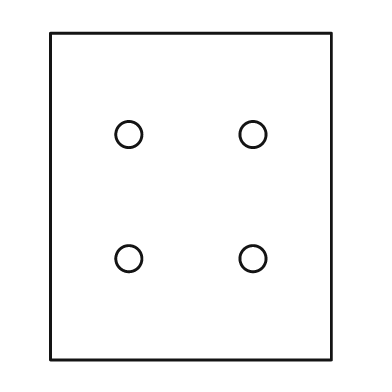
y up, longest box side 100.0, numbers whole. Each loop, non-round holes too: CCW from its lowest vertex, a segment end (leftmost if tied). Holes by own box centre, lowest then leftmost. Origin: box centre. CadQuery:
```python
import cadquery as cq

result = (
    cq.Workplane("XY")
    .moveTo(-43.0, -50.0)
    .lineTo(43.0, -50.0)
    .lineTo(43.0, 50.0)
    .lineTo(-43.0, 50.0)
    .close()
    .moveTo(-19.0, -19.0)
    .circle(4.0)
    .moveTo(19.0, -19.0)
    .circle(4.0)
    .moveTo(-19.0, 19.0)
    .circle(4.0)
    .moveTo(19.0, 19.0)
    .circle(4.0)
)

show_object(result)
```